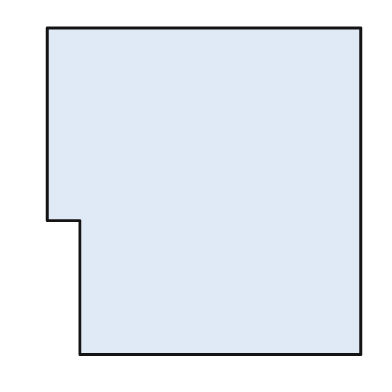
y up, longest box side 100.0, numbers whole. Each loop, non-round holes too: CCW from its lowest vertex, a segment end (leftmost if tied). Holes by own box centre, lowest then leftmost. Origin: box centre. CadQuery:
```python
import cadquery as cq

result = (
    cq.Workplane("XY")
    .moveTo(-38.0, -50.0)
    .lineTo(48.0, -50.0)
    .lineTo(48.0, 50.0)
    .lineTo(-48.0, 50.0)
    .lineTo(-48.0, -9.0)
    .lineTo(-38.0, -9.0)
    .close()
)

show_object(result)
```